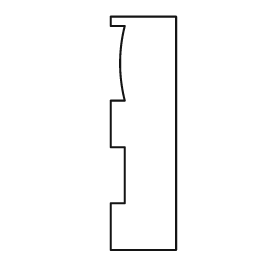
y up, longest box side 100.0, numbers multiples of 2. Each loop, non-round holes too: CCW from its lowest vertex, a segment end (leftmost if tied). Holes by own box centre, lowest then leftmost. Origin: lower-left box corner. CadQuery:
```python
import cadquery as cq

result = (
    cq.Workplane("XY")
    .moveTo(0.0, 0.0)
    .lineTo(28.0, 0.0)
    .lineTo(28.0, 100.0)
    .lineTo(0.0, 100.0)
    .lineTo(0.0, 96.0)
    .lineTo(6.0, 96.0)
    .threePointArc((4.0, 80.0), (6.0, 64.0))
    .lineTo(0.0, 64.0)
    .lineTo(0.0, 44.0)
    .lineTo(6.0, 44.0)
    .lineTo(6.0, 20.0)
    .lineTo(0.0, 20.0)
    .close()
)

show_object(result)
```